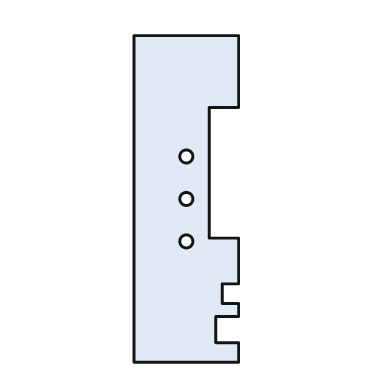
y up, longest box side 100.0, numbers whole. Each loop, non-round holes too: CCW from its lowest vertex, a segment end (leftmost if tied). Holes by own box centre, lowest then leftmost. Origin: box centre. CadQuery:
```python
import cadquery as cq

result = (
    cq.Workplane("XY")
    .moveTo(-16.0, -50.0)
    .lineTo(16.0, -50.0)
    .lineTo(16.0, -44.0)
    .lineTo(9.0, -44.0)
    .lineTo(9.0, -36.0)
    .lineTo(16.0, -36.0)
    .lineTo(16.0, -32.0)
    .lineTo(11.0, -32.0)
    .lineTo(11.0, -26.0)
    .lineTo(16.0, -26.0)
    .lineTo(16.0, -12.0)
    .lineTo(7.0, -12.0)
    .lineTo(7.0, 28.0)
    .lineTo(16.0, 28.0)
    .lineTo(16.0, 50.0)
    .lineTo(-16.0, 50.0)
    .close()
    .moveTo(0.0, -13.0)
    .circle(2.0)
    .moveTo(0.0, 0.0)
    .circle(2.0)
    .moveTo(0.0, 13.0)
    .circle(2.0)
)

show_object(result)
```